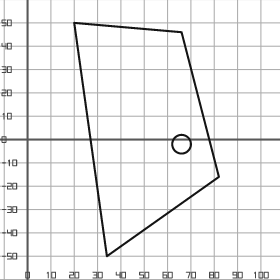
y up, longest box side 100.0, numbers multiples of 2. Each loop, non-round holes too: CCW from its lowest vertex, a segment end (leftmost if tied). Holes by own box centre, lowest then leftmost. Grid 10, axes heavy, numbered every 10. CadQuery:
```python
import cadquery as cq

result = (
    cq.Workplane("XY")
    .moveTo(34.0, -50.0)
    .lineTo(82.0, -16.0)
    .lineTo(66.0, 46.0)
    .lineTo(20.0, 50.0)
    .close()
    .moveTo(66.0, -2.0)
    .circle(4.0)
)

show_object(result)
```